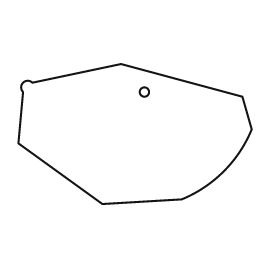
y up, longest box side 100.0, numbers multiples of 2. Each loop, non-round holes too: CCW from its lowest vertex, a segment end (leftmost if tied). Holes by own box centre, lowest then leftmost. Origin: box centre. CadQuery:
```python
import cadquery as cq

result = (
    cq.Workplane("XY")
    .moveTo(-14.0, -30.0)
    .lineTo(20.0, -28.0)
    .threePointArc((38.0, -16.0), (50.0, 2.0))
    .lineTo(46.0, 16.0)
    .lineTo(-6.0, 30.0)
    .lineTo(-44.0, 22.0)
    .threePointArc((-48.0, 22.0), (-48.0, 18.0))
    .lineTo(-50.0, -4.0)
    .close()
    .moveTo(4.0, 18.0)
    .circle(2.0)
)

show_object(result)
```